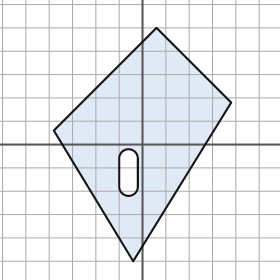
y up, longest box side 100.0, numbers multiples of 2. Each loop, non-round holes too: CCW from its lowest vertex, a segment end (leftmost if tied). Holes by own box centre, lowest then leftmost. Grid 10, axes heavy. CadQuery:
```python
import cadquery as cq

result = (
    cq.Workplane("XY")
    .moveTo(-4.0, -50.0)
    .lineTo(38.0, 18.0)
    .lineTo(6.0, 50.0)
    .lineTo(-38.0, 6.0)
    .close()
    .moveTo(-10.0, -18.0)
    .threePointArc((-6.0, -22.0), (-2.0, -18.0))
    .lineTo(-2.0, -6.0)
    .threePointArc((-6.0, -2.0), (-10.0, -6.0))
    .close()
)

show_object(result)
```